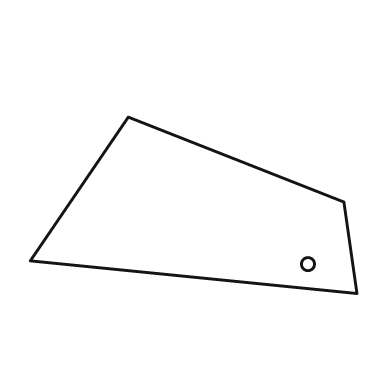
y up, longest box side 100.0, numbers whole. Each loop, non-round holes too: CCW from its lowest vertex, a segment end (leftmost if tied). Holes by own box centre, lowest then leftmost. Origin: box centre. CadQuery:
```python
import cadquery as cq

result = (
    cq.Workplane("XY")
    .moveTo(50.0, -27.0)
    .lineTo(46.0, 1.0)
    .lineTo(-20.0, 27.0)
    .lineTo(-50.0, -17.0)
    .close()
    .moveTo(35.0, -18.0)
    .circle(2.0)
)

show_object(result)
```